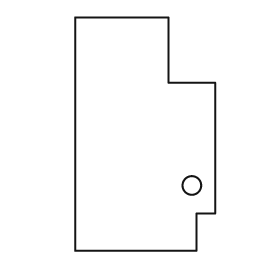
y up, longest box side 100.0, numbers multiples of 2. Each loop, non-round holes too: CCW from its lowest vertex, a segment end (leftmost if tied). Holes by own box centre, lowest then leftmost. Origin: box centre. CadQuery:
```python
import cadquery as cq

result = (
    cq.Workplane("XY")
    .moveTo(-30.0, -50.0)
    .lineTo(22.0, -50.0)
    .lineTo(22.0, -34.0)
    .lineTo(30.0, -34.0)
    .lineTo(30.0, 22.0)
    .lineTo(10.0, 22.0)
    .lineTo(10.0, 50.0)
    .lineTo(-30.0, 50.0)
    .close()
    .moveTo(20.0, -22.0)
    .circle(4.0)
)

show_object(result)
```